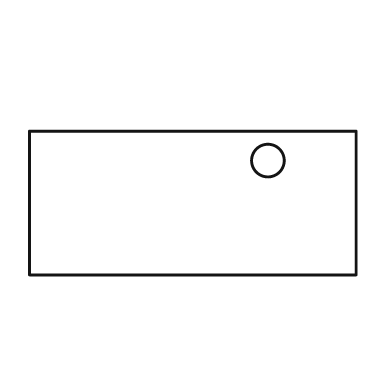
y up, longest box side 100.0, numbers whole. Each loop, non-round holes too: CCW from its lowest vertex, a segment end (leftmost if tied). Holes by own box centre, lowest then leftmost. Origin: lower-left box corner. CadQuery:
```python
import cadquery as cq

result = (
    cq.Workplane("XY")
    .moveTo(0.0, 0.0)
    .lineTo(100.0, 0.0)
    .lineTo(100.0, 44.0)
    .lineTo(0.0, 44.0)
    .close()
    .moveTo(73.0, 35.0)
    .circle(5.0)
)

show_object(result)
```